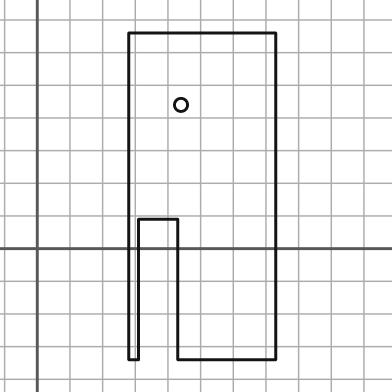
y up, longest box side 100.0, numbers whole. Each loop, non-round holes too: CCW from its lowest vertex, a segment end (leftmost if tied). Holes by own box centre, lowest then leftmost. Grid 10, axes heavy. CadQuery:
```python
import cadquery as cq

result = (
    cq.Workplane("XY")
    .moveTo(28.0, -34.0)
    .lineTo(31.0, -34.0)
    .lineTo(31.0, 9.0)
    .lineTo(43.0, 9.0)
    .lineTo(43.0, -34.0)
    .lineTo(73.0, -34.0)
    .lineTo(73.0, 66.0)
    .lineTo(28.0, 66.0)
    .close()
    .moveTo(44.0, 44.0)
    .circle(2.0)
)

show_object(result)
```